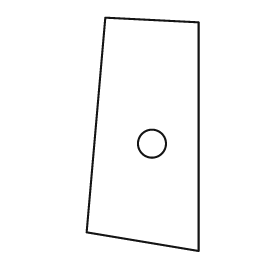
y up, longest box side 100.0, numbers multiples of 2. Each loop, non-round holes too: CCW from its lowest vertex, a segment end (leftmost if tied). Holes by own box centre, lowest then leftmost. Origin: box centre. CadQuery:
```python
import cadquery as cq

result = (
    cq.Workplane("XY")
    .moveTo(24.0, -50.0)
    .lineTo(24.0, 48.0)
    .lineTo(-16.0, 50.0)
    .lineTo(-24.0, -42.0)
    .close()
    .moveTo(4.0, -4.0)
    .circle(6.0)
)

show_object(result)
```